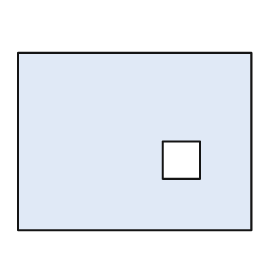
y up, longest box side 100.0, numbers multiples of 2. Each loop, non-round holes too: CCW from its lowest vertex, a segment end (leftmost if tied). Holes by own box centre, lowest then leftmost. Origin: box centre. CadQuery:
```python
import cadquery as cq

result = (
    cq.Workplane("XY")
    .moveTo(-50.0, -38.0)
    .lineTo(50.0, -38.0)
    .lineTo(50.0, 38.0)
    .lineTo(-50.0, 38.0)
    .close()
    .moveTo(12.0, -16.0)
    .lineTo(28.0, -16.0)
    .lineTo(28.0, 0.0)
    .lineTo(12.0, 0.0)
    .close()
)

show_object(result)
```